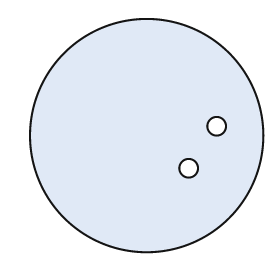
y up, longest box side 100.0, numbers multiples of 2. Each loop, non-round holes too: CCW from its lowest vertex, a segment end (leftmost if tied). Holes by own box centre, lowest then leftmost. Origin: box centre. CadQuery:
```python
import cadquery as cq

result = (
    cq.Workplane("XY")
    .moveTo(0.0, 0.0)
    .circle(50.0)
    .moveTo(18.0, -14.0)
    .circle(4.0)
    .moveTo(30.0, 4.0)
    .circle(4.0)
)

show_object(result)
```